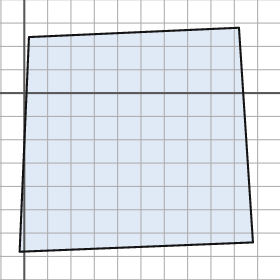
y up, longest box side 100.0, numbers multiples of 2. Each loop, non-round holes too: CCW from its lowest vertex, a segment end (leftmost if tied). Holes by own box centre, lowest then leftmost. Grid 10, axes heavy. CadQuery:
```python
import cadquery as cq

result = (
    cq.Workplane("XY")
    .moveTo(-2.0, -68.0)
    .lineTo(98.0, -64.0)
    .lineTo(92.0, 28.0)
    .lineTo(2.0, 24.0)
    .close()
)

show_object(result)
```